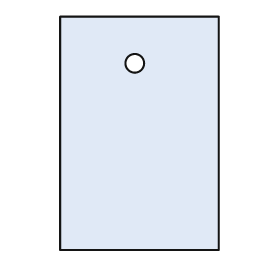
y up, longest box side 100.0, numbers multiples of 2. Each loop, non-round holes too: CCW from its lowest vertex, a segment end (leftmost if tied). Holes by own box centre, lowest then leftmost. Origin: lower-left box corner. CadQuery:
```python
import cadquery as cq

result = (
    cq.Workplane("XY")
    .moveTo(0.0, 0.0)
    .lineTo(68.0, 0.0)
    .lineTo(68.0, 100.0)
    .lineTo(0.0, 100.0)
    .close()
    .moveTo(32.0, 80.0)
    .circle(4.0)
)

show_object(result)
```